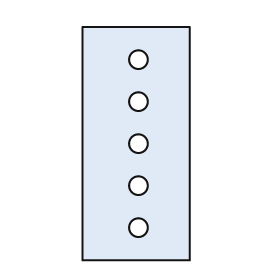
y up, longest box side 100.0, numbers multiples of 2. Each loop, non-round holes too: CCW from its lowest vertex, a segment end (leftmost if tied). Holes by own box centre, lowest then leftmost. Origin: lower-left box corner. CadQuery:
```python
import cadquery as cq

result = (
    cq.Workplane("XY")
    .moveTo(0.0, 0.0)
    .lineTo(46.0, 0.0)
    .lineTo(46.0, 100.0)
    .lineTo(0.0, 100.0)
    .close()
    .moveTo(24.0, 14.0)
    .circle(4.0)
    .moveTo(24.0, 32.0)
    .circle(4.0)
    .moveTo(24.0, 50.0)
    .circle(4.0)
    .moveTo(24.0, 68.0)
    .circle(4.0)
    .moveTo(24.0, 86.0)
    .circle(4.0)
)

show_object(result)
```